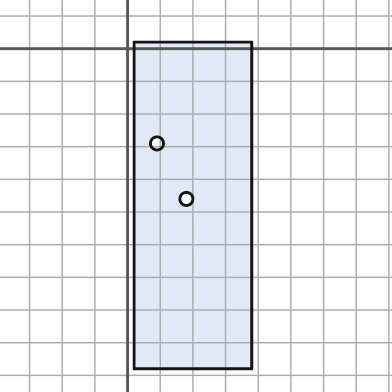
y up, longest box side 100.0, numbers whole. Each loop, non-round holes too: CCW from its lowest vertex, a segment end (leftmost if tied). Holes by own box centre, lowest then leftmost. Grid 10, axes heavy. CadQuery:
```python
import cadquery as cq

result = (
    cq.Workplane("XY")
    .moveTo(2.0, -98.0)
    .lineTo(38.0, -98.0)
    .lineTo(38.0, 2.0)
    .lineTo(2.0, 2.0)
    .close()
    .moveTo(18.0, -46.0)
    .circle(2.0)
    .moveTo(9.0, -29.0)
    .circle(2.0)
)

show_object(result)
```